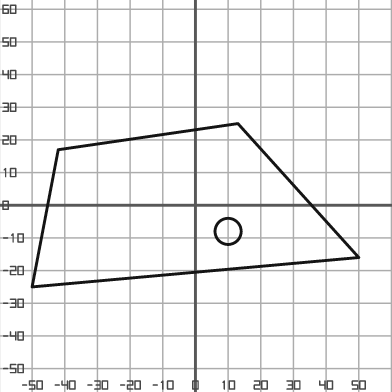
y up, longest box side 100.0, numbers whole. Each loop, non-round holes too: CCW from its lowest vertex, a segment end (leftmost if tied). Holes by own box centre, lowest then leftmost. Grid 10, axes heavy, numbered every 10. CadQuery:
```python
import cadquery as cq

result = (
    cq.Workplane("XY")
    .moveTo(-50.0, -25.0)
    .lineTo(50.0, -16.0)
    .lineTo(13.0, 25.0)
    .lineTo(-42.0, 17.0)
    .close()
    .moveTo(10.0, -8.0)
    .circle(4.0)
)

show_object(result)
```